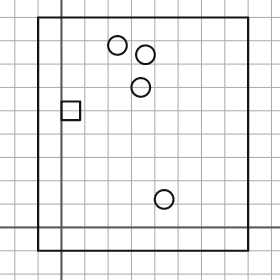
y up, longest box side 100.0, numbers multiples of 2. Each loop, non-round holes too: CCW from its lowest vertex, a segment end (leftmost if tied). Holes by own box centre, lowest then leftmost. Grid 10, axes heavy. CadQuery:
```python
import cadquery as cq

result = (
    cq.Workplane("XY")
    .moveTo(-10.0, -10.0)
    .lineTo(80.0, -10.0)
    .lineTo(80.0, 90.0)
    .lineTo(-10.0, 90.0)
    .close()
    .moveTo(44.0, 12.0)
    .circle(4.0)
    .moveTo(0.0, 46.0)
    .lineTo(8.0, 46.0)
    .lineTo(8.0, 54.0)
    .lineTo(0.0, 54.0)
    .close()
    .moveTo(34.0, 60.0)
    .circle(4.0)
    .moveTo(36.0, 74.0)
    .circle(4.0)
    .moveTo(24.0, 78.0)
    .circle(4.0)
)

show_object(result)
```